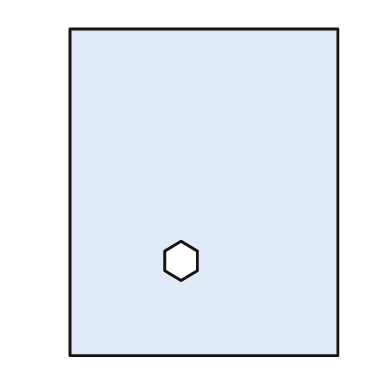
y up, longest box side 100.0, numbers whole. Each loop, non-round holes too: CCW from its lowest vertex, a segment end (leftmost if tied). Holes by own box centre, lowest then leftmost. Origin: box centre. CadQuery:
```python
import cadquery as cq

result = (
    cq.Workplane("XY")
    .moveTo(-41.0, -50.0)
    .lineTo(41.0, -50.0)
    .lineTo(41.0, 50.0)
    .lineTo(-41.0, 50.0)
    .close()
    .moveTo(-7.0, -27.0)
    .lineTo(-2.0, -24.0)
    .lineTo(-2.0, -18.0)
    .lineTo(-7.0, -15.0)
    .lineTo(-12.0, -18.0)
    .lineTo(-12.0, -24.0)
    .close()
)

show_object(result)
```